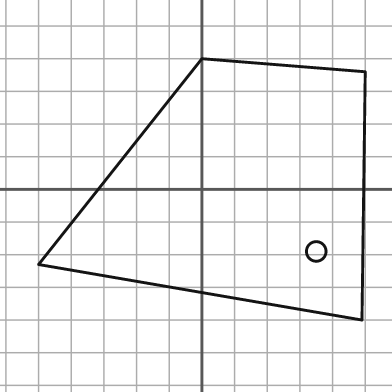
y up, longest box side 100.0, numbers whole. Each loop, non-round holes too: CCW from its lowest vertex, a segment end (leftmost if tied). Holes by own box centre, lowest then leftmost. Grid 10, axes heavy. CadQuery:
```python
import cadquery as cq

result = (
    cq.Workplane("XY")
    .moveTo(49.0, -40.0)
    .lineTo(50.0, 36.0)
    .lineTo(0.0, 40.0)
    .lineTo(-50.0, -23.0)
    .close()
    .moveTo(35.0, -19.0)
    .circle(3.0)
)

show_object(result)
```